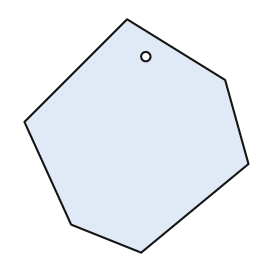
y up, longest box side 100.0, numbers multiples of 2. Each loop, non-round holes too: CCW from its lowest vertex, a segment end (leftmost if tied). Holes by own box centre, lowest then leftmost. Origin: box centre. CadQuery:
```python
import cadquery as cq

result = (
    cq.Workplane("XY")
    .moveTo(2.0, -50.0)
    .lineTo(48.0, -12.0)
    .lineTo(38.0, 24.0)
    .lineTo(-4.0, 50.0)
    .lineTo(-48.0, 6.0)
    .lineTo(-28.0, -38.0)
    .close()
    .moveTo(4.0, 34.0)
    .circle(2.0)
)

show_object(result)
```